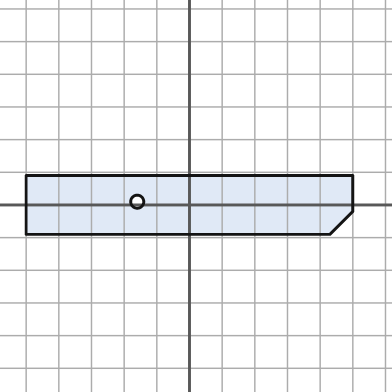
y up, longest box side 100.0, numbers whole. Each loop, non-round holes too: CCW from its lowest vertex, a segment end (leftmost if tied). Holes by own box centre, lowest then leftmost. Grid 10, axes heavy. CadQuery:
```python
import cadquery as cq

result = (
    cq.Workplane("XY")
    .moveTo(-50.0, -9.0)
    .lineTo(43.0, -9.0)
    .lineTo(50.0, -2.0)
    .lineTo(50.0, 9.0)
    .lineTo(-50.0, 9.0)
    .close()
    .moveTo(-16.0, 1.0)
    .circle(2.0)
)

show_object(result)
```